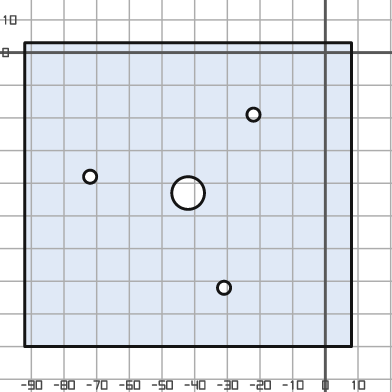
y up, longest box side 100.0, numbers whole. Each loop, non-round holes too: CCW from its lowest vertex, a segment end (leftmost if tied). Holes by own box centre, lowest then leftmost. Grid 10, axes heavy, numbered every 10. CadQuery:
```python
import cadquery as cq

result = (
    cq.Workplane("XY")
    .moveTo(-92.0, -90.0)
    .lineTo(8.0, -90.0)
    .lineTo(8.0, 3.0)
    .lineTo(-92.0, 3.0)
    .close()
    .moveTo(-31.0, -72.0)
    .circle(2.0)
    .moveTo(-42.0, -43.0)
    .circle(5.0)
    .moveTo(-72.0, -38.0)
    .circle(2.0)
    .moveTo(-22.0, -19.0)
    .circle(2.0)
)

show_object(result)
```